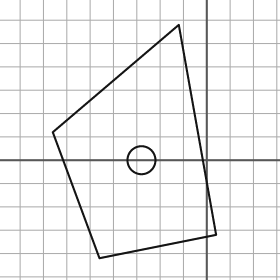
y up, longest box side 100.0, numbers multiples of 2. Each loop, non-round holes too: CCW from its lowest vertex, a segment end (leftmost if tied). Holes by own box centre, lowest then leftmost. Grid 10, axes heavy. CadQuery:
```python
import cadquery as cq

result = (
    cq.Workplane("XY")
    .moveTo(-46.0, -42.0)
    .lineTo(4.0, -32.0)
    .lineTo(-12.0, 58.0)
    .lineTo(-66.0, 12.0)
    .close()
    .moveTo(-28.0, 0.0)
    .circle(6.0)
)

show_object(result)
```